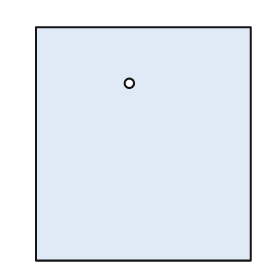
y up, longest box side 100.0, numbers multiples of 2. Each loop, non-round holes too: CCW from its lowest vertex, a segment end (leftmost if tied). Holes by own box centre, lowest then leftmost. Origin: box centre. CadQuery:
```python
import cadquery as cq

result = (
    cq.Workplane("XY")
    .moveTo(-46.0, -50.0)
    .lineTo(46.0, -50.0)
    .lineTo(46.0, 50.0)
    .lineTo(-46.0, 50.0)
    .close()
    .moveTo(-6.0, 26.0)
    .circle(2.0)
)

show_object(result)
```